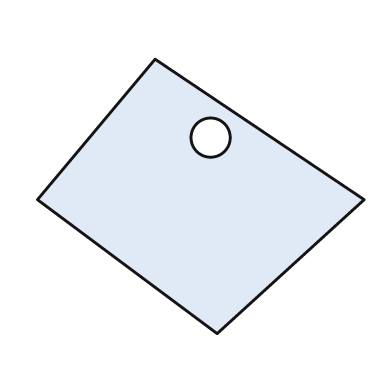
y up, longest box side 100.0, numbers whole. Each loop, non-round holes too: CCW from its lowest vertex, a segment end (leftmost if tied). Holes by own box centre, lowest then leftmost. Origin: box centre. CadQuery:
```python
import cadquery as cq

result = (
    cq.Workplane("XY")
    .moveTo(5.0, -42.0)
    .lineTo(50.0, -1.0)
    .lineTo(-14.0, 42.0)
    .lineTo(-50.0, -1.0)
    .close()
    .moveTo(3.0, 18.0)
    .circle(6.0)
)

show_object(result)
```